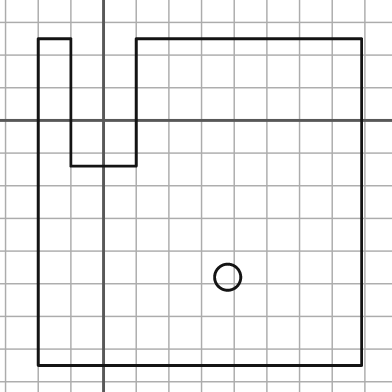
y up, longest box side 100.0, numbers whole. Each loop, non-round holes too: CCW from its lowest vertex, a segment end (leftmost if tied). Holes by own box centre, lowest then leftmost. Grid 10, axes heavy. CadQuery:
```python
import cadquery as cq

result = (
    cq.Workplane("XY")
    .moveTo(-20.0, -75.0)
    .lineTo(79.0, -75.0)
    .lineTo(79.0, 25.0)
    .lineTo(10.0, 25.0)
    .lineTo(10.0, -14.0)
    .lineTo(-10.0, -14.0)
    .lineTo(-10.0, 25.0)
    .lineTo(-20.0, 25.0)
    .close()
    .moveTo(38.0, -48.0)
    .circle(4.0)
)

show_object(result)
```